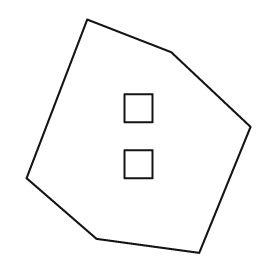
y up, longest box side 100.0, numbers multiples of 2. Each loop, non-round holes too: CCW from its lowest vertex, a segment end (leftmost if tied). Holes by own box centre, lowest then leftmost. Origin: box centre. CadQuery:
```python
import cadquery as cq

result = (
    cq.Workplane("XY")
    .moveTo(26.0, -50.0)
    .lineTo(48.0, 4.0)
    .lineTo(14.0, 36.0)
    .lineTo(-22.0, 50.0)
    .lineTo(-48.0, -18.0)
    .lineTo(-18.0, -44.0)
    .close()
    .moveTo(-6.0, -18.0)
    .lineTo(6.0, -18.0)
    .lineTo(6.0, -6.0)
    .lineTo(-6.0, -6.0)
    .close()
    .moveTo(-6.0, 6.0)
    .lineTo(6.0, 6.0)
    .lineTo(6.0, 18.0)
    .lineTo(-6.0, 18.0)
    .close()
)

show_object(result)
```